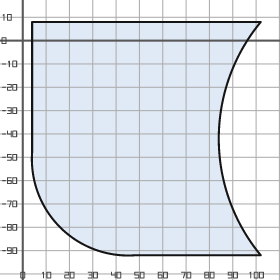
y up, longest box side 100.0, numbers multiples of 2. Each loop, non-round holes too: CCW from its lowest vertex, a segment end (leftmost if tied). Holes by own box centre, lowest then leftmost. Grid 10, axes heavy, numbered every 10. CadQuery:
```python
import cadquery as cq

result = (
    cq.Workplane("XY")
    .moveTo(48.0, -92.0)
    .lineTo(102.0, -92.0)
    .threePointArc((84.0, -42.0), (102.0, 8.0))
    .lineTo(4.0, 8.0)
    .lineTo(4.0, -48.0)
    .threePointArc((16.0, -80.0), (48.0, -92.0))
    .close()
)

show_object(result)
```